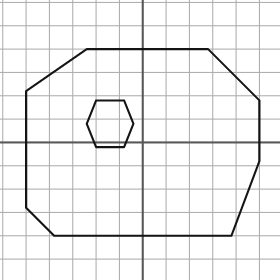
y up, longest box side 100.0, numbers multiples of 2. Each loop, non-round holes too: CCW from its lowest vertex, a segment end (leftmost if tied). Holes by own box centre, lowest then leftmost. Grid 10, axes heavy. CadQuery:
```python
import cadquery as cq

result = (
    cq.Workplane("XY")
    .moveTo(-38.0, -40.0)
    .lineTo(38.0, -40.0)
    .lineTo(50.0, -8.0)
    .lineTo(50.0, 18.0)
    .lineTo(28.0, 40.0)
    .lineTo(-24.0, 40.0)
    .lineTo(-50.0, 22.0)
    .lineTo(-50.0, -28.0)
    .close()
    .moveTo(-20.0, -2.0)
    .lineTo(-8.0, -2.0)
    .lineTo(-4.0, 8.0)
    .lineTo(-8.0, 18.0)
    .lineTo(-20.0, 18.0)
    .lineTo(-24.0, 8.0)
    .close()
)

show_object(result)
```